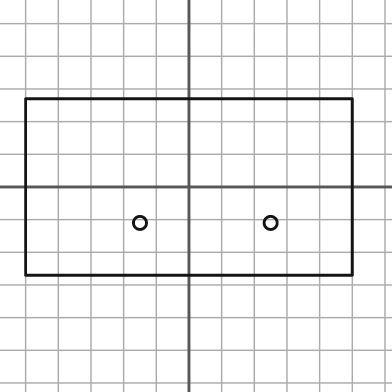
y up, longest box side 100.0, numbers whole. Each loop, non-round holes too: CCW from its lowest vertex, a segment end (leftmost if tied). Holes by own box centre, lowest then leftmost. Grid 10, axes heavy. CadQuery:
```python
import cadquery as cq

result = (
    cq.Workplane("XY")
    .moveTo(-50.0, -27.0)
    .lineTo(50.0, -27.0)
    .lineTo(50.0, 27.0)
    .lineTo(-50.0, 27.0)
    .close()
    .moveTo(-15.0, -11.0)
    .circle(2.0)
    .moveTo(25.0, -11.0)
    .circle(2.0)
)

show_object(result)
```